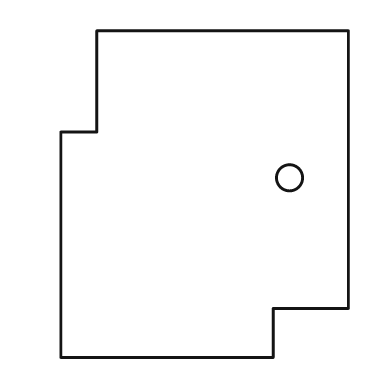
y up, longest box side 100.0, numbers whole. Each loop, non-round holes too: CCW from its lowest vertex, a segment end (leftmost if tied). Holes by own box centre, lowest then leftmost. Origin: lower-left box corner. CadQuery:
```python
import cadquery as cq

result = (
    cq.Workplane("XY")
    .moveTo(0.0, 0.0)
    .lineTo(65.0, 0.0)
    .lineTo(65.0, 15.0)
    .lineTo(88.0, 15.0)
    .lineTo(88.0, 100.0)
    .lineTo(11.0, 100.0)
    .lineTo(11.0, 69.0)
    .lineTo(0.0, 69.0)
    .close()
    .moveTo(70.0, 55.0)
    .circle(4.0)
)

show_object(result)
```